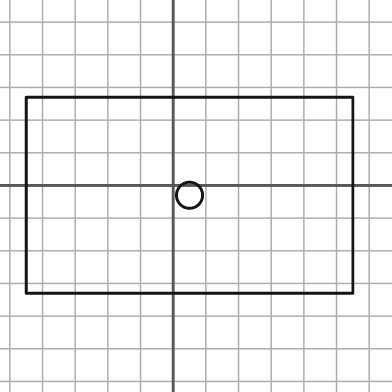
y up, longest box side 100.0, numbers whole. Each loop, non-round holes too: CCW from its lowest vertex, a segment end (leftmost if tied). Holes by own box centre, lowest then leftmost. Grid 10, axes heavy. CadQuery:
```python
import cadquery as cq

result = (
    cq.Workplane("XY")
    .moveTo(-45.0, -33.0)
    .lineTo(55.0, -33.0)
    .lineTo(55.0, 27.0)
    .lineTo(-45.0, 27.0)
    .close()
    .moveTo(5.0, -3.0)
    .circle(4.0)
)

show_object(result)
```